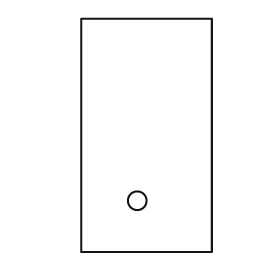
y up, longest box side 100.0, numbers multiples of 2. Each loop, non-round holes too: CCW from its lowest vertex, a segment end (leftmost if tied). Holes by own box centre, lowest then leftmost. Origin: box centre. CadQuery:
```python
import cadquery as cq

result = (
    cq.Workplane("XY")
    .moveTo(-28.0, -50.0)
    .lineTo(28.0, -50.0)
    .lineTo(28.0, 50.0)
    .lineTo(-28.0, 50.0)
    .close()
    .moveTo(-4.0, -28.0)
    .circle(4.0)
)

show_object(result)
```